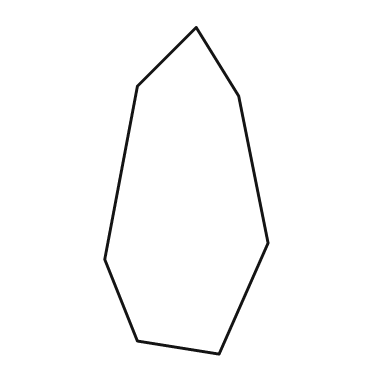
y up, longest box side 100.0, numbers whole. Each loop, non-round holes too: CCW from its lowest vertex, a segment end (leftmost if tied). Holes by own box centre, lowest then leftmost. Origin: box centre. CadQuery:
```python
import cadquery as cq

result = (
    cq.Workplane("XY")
    .moveTo(10.0, -50.0)
    .lineTo(25.0, -16.0)
    .lineTo(16.0, 29.0)
    .lineTo(3.0, 50.0)
    .lineTo(-15.0, 32.0)
    .lineTo(-25.0, -21.0)
    .lineTo(-15.0, -46.0)
    .close()
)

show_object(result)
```